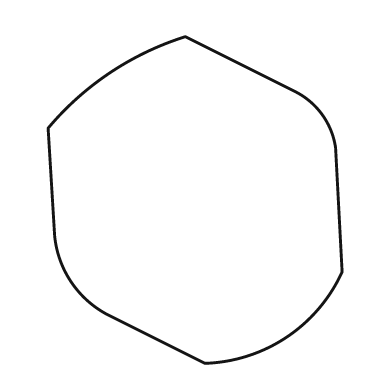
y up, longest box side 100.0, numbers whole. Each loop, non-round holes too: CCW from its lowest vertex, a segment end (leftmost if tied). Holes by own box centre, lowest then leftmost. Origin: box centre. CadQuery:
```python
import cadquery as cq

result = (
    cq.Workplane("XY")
    .moveTo(3.0, -50.0)
    .threePointArc((28.0, -42.0), (45.0, -22.0))
    .lineTo(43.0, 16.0)
    .threePointArc((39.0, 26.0), (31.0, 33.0))
    .lineTo(-3.0, 50.0)
    .threePointArc((-26.0, 39.0), (-45.0, 22.0))
    .lineTo(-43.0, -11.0)
    .threePointArc((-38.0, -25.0), (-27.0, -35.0))
    .close()
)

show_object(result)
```